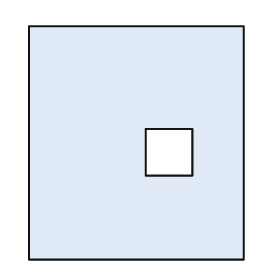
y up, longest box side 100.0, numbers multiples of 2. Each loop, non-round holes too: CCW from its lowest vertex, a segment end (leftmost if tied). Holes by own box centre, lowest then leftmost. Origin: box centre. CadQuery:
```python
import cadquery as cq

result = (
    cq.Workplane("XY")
    .moveTo(-46.0, -50.0)
    .lineTo(46.0, -50.0)
    .lineTo(46.0, 50.0)
    .lineTo(-46.0, 50.0)
    .close()
    .moveTo(4.0, -14.0)
    .lineTo(24.0, -14.0)
    .lineTo(24.0, 6.0)
    .lineTo(4.0, 6.0)
    .close()
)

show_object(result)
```